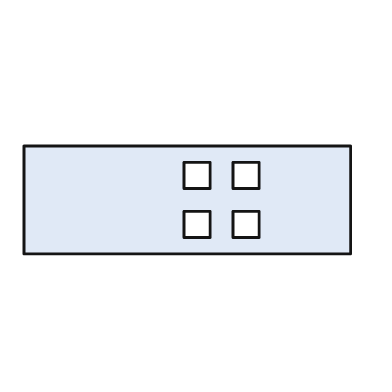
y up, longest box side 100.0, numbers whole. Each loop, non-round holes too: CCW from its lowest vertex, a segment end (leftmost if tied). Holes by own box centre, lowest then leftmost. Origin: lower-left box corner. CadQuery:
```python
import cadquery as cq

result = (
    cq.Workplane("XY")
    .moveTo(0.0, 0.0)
    .lineTo(100.0, 0.0)
    .lineTo(100.0, 33.0)
    .lineTo(0.0, 33.0)
    .close()
    .moveTo(49.0, 5.0)
    .lineTo(57.0, 5.0)
    .lineTo(57.0, 13.0)
    .lineTo(49.0, 13.0)
    .close()
    .moveTo(64.0, 5.0)
    .lineTo(72.0, 5.0)
    .lineTo(72.0, 13.0)
    .lineTo(64.0, 13.0)
    .close()
    .moveTo(49.0, 20.0)
    .lineTo(57.0, 20.0)
    .lineTo(57.0, 28.0)
    .lineTo(49.0, 28.0)
    .close()
    .moveTo(64.0, 20.0)
    .lineTo(72.0, 20.0)
    .lineTo(72.0, 28.0)
    .lineTo(64.0, 28.0)
    .close()
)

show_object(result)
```